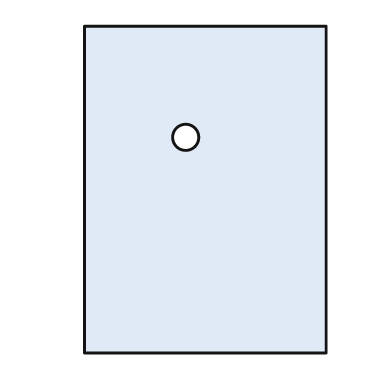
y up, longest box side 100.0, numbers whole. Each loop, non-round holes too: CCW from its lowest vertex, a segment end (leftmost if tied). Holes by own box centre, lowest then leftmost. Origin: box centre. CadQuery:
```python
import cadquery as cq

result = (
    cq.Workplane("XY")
    .moveTo(-37.0, -50.0)
    .lineTo(37.0, -50.0)
    .lineTo(37.0, 50.0)
    .lineTo(-37.0, 50.0)
    .close()
    .moveTo(-6.0, 16.0)
    .circle(4.0)
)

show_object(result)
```